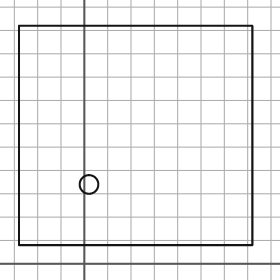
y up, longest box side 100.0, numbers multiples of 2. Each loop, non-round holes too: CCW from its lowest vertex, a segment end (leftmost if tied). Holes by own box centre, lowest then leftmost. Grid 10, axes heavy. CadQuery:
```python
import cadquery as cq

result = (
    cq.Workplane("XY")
    .moveTo(-28.0, 8.0)
    .lineTo(72.0, 8.0)
    .lineTo(72.0, 102.0)
    .lineTo(-28.0, 102.0)
    .close()
    .moveTo(2.0, 34.0)
    .circle(4.0)
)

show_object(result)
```